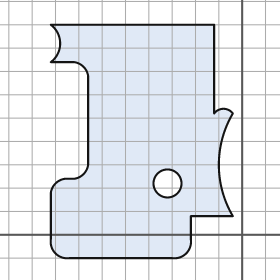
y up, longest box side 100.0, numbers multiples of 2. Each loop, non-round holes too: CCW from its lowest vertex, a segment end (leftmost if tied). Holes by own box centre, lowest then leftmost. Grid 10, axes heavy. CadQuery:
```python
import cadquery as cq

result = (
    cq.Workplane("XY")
    .moveTo(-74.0, -10.0)
    .lineTo(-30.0, -10.0)
    .threePointArc((-24.0, -8.0), (-22.0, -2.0))
    .lineTo(-22.0, 8.0)
    .lineTo(-4.0, 8.0)
    .threePointArc((-10.0, 30.0), (-4.0, 52.0))
    .threePointArc((-8.0, 54.0), (-12.0, 52.0))
    .lineTo(-12.0, 90.0)
    .lineTo(-82.0, 90.0)
    .threePointArc((-78.0, 82.0), (-82.0, 74.0))
    .lineTo(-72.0, 74.0)
    .threePointArc((-68.0, 72.0), (-66.0, 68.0))
    .lineTo(-66.0, 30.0)
    .threePointArc((-68.0, 26.0), (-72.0, 24.0))
    .lineTo(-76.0, 24.0)
    .threePointArc((-80.0, 22.0), (-82.0, 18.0))
    .lineTo(-82.0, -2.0)
    .threePointArc((-80.0, -8.0), (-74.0, -10.0))
    .close()
    .moveTo(-32.0, 22.0)
    .circle(6.0)
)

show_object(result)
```